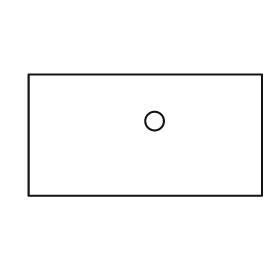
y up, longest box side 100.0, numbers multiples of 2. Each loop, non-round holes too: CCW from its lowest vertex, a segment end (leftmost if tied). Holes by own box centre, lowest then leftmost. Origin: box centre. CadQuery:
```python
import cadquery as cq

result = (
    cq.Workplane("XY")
    .moveTo(-50.0, -26.0)
    .lineTo(50.0, -26.0)
    .lineTo(50.0, 26.0)
    .lineTo(-50.0, 26.0)
    .close()
    .moveTo(4.0, 6.0)
    .circle(4.0)
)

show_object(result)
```